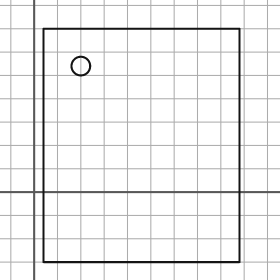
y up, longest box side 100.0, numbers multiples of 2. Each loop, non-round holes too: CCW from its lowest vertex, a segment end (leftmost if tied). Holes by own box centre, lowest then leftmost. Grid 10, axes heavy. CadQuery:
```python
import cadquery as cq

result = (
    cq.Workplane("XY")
    .moveTo(4.0, -30.0)
    .lineTo(88.0, -30.0)
    .lineTo(88.0, 70.0)
    .lineTo(4.0, 70.0)
    .close()
    .moveTo(20.0, 54.0)
    .circle(4.0)
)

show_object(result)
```